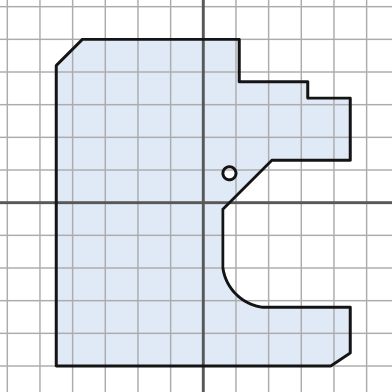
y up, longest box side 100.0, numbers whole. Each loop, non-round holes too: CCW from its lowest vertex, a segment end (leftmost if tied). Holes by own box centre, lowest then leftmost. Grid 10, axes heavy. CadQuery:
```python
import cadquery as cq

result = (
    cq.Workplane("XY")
    .moveTo(-45.0, -50.0)
    .lineTo(39.0, -50.0)
    .lineTo(45.0, -46.0)
    .lineTo(45.0, -32.0)
    .lineTo(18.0, -32.0)
    .threePointArc((10.0, -28.0), (6.0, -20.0))
    .lineTo(6.0, -2.0)
    .lineTo(21.0, 13.0)
    .lineTo(45.0, 13.0)
    .lineTo(45.0, 32.0)
    .lineTo(32.0, 32.0)
    .lineTo(32.0, 37.0)
    .lineTo(11.0, 37.0)
    .lineTo(11.0, 50.0)
    .lineTo(-37.0, 50.0)
    .lineTo(-45.0, 42.0)
    .close()
    .moveTo(8.0, 9.0)
    .circle(2.0)
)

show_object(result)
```